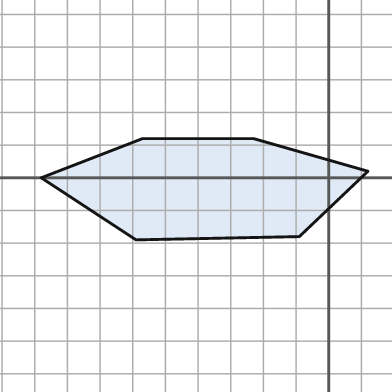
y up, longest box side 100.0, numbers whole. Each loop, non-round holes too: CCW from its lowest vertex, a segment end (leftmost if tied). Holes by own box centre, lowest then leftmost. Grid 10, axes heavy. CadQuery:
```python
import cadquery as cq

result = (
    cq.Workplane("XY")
    .moveTo(-59.0, -19.0)
    .lineTo(-9.0, -18.0)
    .lineTo(12.0, 2.0)
    .lineTo(-23.0, 12.0)
    .lineTo(-57.0, 12.0)
    .lineTo(-88.0, 0.0)
    .close()
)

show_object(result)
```